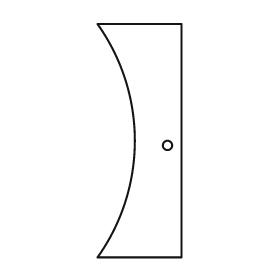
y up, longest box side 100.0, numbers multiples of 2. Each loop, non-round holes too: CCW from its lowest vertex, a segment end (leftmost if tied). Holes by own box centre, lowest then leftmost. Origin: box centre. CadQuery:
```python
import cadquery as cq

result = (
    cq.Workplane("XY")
    .moveTo(-18.0, -50.0)
    .lineTo(18.0, -50.0)
    .lineTo(18.0, 50.0)
    .lineTo(-18.0, 50.0)
    .threePointArc((-2.0, 0.0), (-18.0, -50.0))
    .close()
    .moveTo(12.0, -2.0)
    .circle(2.0)
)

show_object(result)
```